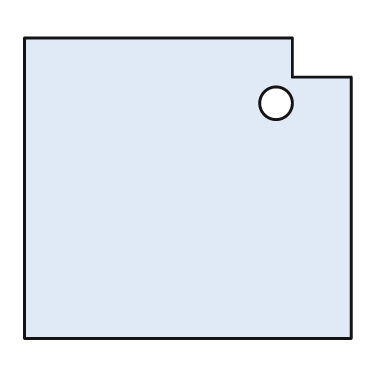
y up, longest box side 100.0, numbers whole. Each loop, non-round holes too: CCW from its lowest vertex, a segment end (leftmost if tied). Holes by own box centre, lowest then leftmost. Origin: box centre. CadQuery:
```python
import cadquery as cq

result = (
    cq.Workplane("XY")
    .moveTo(-50.0, -46.0)
    .lineTo(50.0, -46.0)
    .lineTo(50.0, 34.0)
    .lineTo(32.0, 34.0)
    .lineTo(32.0, 46.0)
    .lineTo(-50.0, 46.0)
    .close()
    .moveTo(27.0, 26.0)
    .circle(5.0)
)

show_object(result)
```